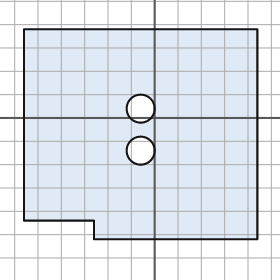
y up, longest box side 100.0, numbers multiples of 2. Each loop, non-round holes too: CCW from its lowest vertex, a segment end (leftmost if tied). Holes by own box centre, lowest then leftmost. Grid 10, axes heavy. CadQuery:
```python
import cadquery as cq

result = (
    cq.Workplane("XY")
    .moveTo(-26.0, -52.0)
    .lineTo(44.0, -52.0)
    .lineTo(44.0, 38.0)
    .lineTo(-56.0, 38.0)
    .lineTo(-56.0, -44.0)
    .lineTo(-26.0, -44.0)
    .close()
    .moveTo(-6.0, -14.0)
    .circle(6.0)
    .moveTo(-6.0, 4.0)
    .circle(6.0)
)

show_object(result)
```